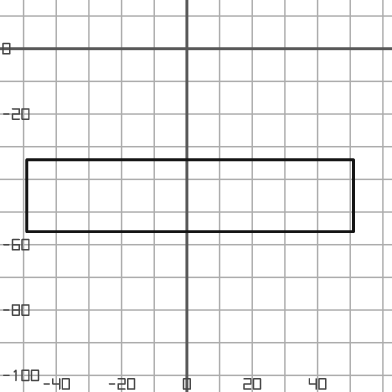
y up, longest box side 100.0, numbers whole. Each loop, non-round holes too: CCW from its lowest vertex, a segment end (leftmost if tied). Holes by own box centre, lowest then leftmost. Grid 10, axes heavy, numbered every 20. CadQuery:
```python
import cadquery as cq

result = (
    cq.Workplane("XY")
    .moveTo(-49.0, -56.0)
    .lineTo(51.0, -56.0)
    .lineTo(51.0, -34.0)
    .lineTo(-49.0, -34.0)
    .close()
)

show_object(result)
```